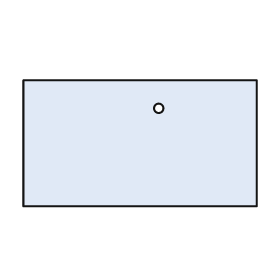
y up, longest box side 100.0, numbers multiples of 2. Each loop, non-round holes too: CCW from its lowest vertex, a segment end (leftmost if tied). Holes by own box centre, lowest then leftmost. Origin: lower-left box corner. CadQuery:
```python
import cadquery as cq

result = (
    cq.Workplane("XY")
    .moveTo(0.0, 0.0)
    .lineTo(100.0, 0.0)
    .lineTo(100.0, 54.0)
    .lineTo(0.0, 54.0)
    .close()
    .moveTo(58.0, 42.0)
    .circle(2.0)
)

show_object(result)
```